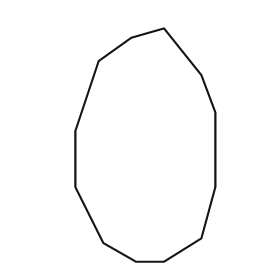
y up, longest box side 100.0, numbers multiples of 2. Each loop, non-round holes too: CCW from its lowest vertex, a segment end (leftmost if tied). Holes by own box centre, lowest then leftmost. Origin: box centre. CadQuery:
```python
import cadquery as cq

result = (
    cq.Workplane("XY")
    .moveTo(-4.0, -50.0)
    .lineTo(8.0, -50.0)
    .lineTo(24.0, -40.0)
    .lineTo(30.0, -18.0)
    .lineTo(30.0, 14.0)
    .lineTo(24.0, 30.0)
    .lineTo(8.0, 50.0)
    .lineTo(-6.0, 46.0)
    .lineTo(-20.0, 36.0)
    .lineTo(-30.0, 6.0)
    .lineTo(-30.0, -18.0)
    .lineTo(-18.0, -42.0)
    .close()
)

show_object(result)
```